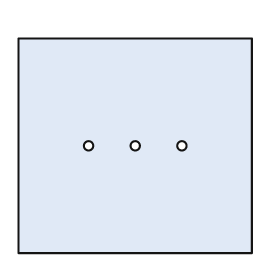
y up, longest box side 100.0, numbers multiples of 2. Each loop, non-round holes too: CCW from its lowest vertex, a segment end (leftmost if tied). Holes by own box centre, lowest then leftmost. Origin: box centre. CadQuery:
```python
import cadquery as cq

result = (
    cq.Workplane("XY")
    .moveTo(-50.0, -46.0)
    .lineTo(50.0, -46.0)
    .lineTo(50.0, 46.0)
    .lineTo(-50.0, 46.0)
    .close()
    .moveTo(-20.0, 0.0)
    .circle(2.0)
    .moveTo(0.0, 0.0)
    .circle(2.0)
    .moveTo(20.0, 0.0)
    .circle(2.0)
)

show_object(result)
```